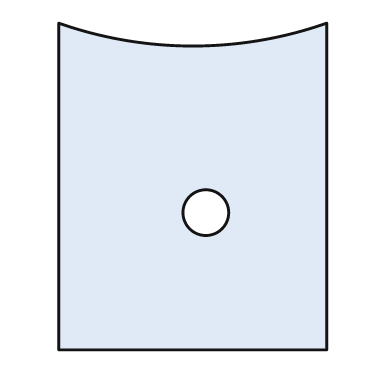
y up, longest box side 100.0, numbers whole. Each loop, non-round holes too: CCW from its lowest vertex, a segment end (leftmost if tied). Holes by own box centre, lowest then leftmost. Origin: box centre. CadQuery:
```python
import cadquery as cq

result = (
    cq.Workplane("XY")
    .moveTo(-41.0, -50.0)
    .lineTo(41.0, -50.0)
    .lineTo(41.0, 50.0)
    .threePointArc((0.0, 43.0), (-41.0, 50.0))
    .close()
    .moveTo(4.0, -8.0)
    .circle(7.0)
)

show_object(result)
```